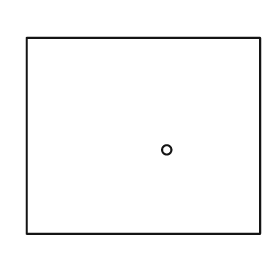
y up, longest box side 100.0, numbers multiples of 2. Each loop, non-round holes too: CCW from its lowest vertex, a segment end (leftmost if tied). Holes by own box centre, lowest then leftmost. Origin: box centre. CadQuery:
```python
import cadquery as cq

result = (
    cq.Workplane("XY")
    .moveTo(-50.0, -42.0)
    .lineTo(50.0, -42.0)
    .lineTo(50.0, 42.0)
    .lineTo(-50.0, 42.0)
    .close()
    .moveTo(10.0, -6.0)
    .circle(2.0)
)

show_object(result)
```